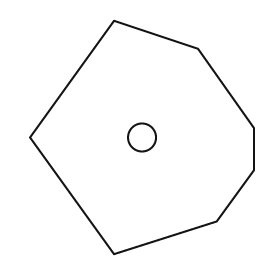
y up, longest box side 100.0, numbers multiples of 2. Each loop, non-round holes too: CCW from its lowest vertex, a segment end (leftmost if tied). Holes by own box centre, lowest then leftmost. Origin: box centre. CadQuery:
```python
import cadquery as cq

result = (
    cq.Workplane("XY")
    .moveTo(-12.0, -50.0)
    .lineTo(32.0, -36.0)
    .lineTo(48.0, -14.0)
    .lineTo(48.0, 4.0)
    .lineTo(24.0, 38.0)
    .lineTo(-12.0, 50.0)
    .lineTo(-48.0, 0.0)
    .close()
    .moveTo(0.0, 0.0)
    .circle(6.0)
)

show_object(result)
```